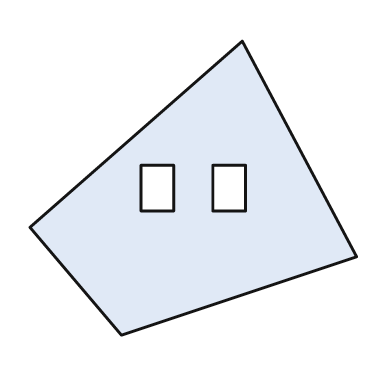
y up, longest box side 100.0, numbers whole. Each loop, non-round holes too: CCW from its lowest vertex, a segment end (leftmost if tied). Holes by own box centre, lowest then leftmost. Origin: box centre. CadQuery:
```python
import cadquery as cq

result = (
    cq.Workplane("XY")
    .moveTo(-22.0, -45.0)
    .lineTo(50.0, -21.0)
    .lineTo(15.0, 45.0)
    .lineTo(-50.0, -12.0)
    .close()
    .moveTo(-16.0, -7.0)
    .lineTo(-6.0, -7.0)
    .lineTo(-6.0, 7.0)
    .lineTo(-16.0, 7.0)
    .close()
    .moveTo(6.0, -7.0)
    .lineTo(16.0, -7.0)
    .lineTo(16.0, 7.0)
    .lineTo(6.0, 7.0)
    .close()
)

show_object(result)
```